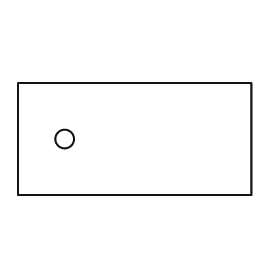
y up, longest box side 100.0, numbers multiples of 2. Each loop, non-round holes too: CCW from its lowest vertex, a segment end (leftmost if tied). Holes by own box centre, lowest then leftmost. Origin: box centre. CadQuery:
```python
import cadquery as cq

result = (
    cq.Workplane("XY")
    .moveTo(-50.0, -24.0)
    .lineTo(50.0, -24.0)
    .lineTo(50.0, 24.0)
    .lineTo(-50.0, 24.0)
    .close()
    .moveTo(-30.0, 0.0)
    .circle(4.0)
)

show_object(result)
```